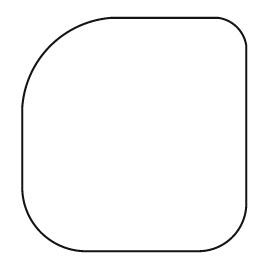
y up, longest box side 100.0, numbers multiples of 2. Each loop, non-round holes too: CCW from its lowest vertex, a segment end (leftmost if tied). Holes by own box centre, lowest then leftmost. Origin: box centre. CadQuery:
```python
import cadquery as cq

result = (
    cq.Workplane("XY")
    .moveTo(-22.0, -50.0)
    .lineTo(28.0, -50.0)
    .threePointArc((42.0, -44.0), (48.0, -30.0))
    .lineTo(48.0, 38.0)
    .threePointArc((44.0, 46.0), (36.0, 50.0))
    .lineTo(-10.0, 50.0)
    .threePointArc((-36.0, 38.0), (-48.0, 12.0))
    .lineTo(-48.0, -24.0)
    .threePointArc((-40.0, -42.0), (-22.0, -50.0))
    .close()
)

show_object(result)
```